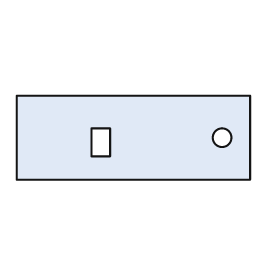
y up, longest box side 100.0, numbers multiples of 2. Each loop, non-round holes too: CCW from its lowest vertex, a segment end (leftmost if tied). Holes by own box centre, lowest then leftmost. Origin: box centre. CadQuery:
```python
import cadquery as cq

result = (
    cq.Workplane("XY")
    .moveTo(-50.0, -18.0)
    .lineTo(50.0, -18.0)
    .lineTo(50.0, 18.0)
    .lineTo(-50.0, 18.0)
    .close()
    .moveTo(-18.0, -8.0)
    .lineTo(-10.0, -8.0)
    .lineTo(-10.0, 4.0)
    .lineTo(-18.0, 4.0)
    .close()
    .moveTo(38.0, 0.0)
    .circle(4.0)
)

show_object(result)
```